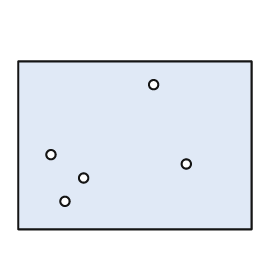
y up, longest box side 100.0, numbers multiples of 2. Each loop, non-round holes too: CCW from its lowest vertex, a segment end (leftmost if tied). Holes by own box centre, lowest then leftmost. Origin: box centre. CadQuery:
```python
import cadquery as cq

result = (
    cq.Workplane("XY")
    .moveTo(-50.0, -36.0)
    .lineTo(50.0, -36.0)
    .lineTo(50.0, 36.0)
    .lineTo(-50.0, 36.0)
    .close()
    .moveTo(-30.0, -24.0)
    .circle(2.0)
    .moveTo(-22.0, -14.0)
    .circle(2.0)
    .moveTo(22.0, -8.0)
    .circle(2.0)
    .moveTo(-36.0, -4.0)
    .circle(2.0)
    .moveTo(8.0, 26.0)
    .circle(2.0)
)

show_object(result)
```